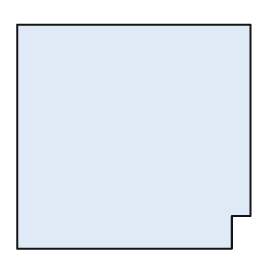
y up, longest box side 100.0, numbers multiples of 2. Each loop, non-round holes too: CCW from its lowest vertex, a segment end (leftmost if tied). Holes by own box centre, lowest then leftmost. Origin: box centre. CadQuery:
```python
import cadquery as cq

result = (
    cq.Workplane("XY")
    .moveTo(-50.0, -48.0)
    .lineTo(42.0, -48.0)
    .lineTo(42.0, -34.0)
    .lineTo(50.0, -34.0)
    .lineTo(50.0, 48.0)
    .lineTo(-50.0, 48.0)
    .close()
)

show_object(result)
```